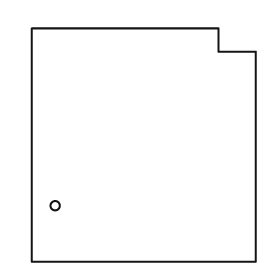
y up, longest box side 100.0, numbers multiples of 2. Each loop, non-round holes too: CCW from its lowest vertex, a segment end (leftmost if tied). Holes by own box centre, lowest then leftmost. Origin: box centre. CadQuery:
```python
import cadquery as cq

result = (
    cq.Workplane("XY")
    .moveTo(-48.0, -50.0)
    .lineTo(48.0, -50.0)
    .lineTo(48.0, 40.0)
    .lineTo(32.0, 40.0)
    .lineTo(32.0, 50.0)
    .lineTo(-48.0, 50.0)
    .close()
    .moveTo(-38.0, -26.0)
    .circle(2.0)
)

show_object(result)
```